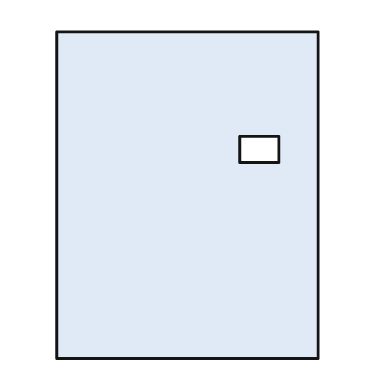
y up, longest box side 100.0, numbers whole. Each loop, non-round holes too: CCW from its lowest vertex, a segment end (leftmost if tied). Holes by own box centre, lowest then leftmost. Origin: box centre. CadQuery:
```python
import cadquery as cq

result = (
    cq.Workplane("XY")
    .moveTo(-40.0, -50.0)
    .lineTo(40.0, -50.0)
    .lineTo(40.0, 50.0)
    .lineTo(-40.0, 50.0)
    .close()
    .moveTo(16.0, 10.0)
    .lineTo(28.0, 10.0)
    .lineTo(28.0, 18.0)
    .lineTo(16.0, 18.0)
    .close()
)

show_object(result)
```